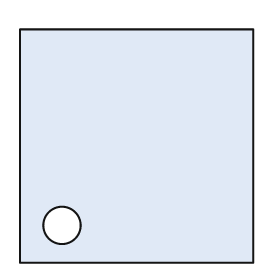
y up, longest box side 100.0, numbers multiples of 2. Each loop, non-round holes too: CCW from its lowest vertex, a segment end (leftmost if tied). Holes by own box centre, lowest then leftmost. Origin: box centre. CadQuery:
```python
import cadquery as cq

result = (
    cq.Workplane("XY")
    .moveTo(-50.0, -50.0)
    .lineTo(50.0, -50.0)
    .lineTo(50.0, 50.0)
    .lineTo(-50.0, 50.0)
    .close()
    .moveTo(-32.0, -34.0)
    .circle(8.0)
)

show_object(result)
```